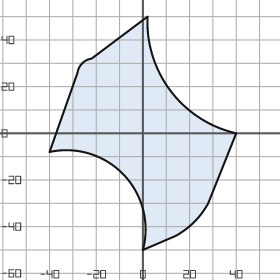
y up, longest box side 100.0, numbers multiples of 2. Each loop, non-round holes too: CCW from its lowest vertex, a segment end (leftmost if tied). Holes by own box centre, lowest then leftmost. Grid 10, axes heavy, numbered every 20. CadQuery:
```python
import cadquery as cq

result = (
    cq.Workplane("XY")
    .moveTo(0.0, -50.0)
    .lineTo(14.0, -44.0)
    .threePointArc((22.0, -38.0), (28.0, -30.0))
    .lineTo(40.0, 0.0)
    .threePointArc((12.0, 18.0), (2.0, 50.0))
    .lineTo(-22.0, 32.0)
    .threePointArc((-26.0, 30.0), (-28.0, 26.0))
    .lineTo(-40.0, -8.0)
    .threePointArc((-8.0, -18.0), (0.0, -50.0))
    .close()
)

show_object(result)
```